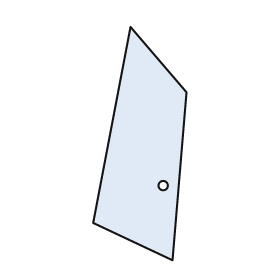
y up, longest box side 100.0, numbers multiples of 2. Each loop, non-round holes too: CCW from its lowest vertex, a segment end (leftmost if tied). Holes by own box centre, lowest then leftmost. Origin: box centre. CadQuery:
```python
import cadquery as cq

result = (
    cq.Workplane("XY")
    .moveTo(14.0, -50.0)
    .lineTo(20.0, 22.0)
    .lineTo(-4.0, 50.0)
    .lineTo(-20.0, -34.0)
    .close()
    .moveTo(10.0, -18.0)
    .circle(2.0)
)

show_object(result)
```